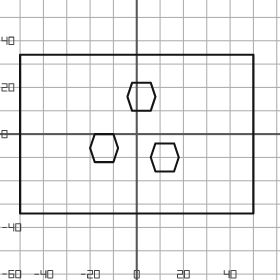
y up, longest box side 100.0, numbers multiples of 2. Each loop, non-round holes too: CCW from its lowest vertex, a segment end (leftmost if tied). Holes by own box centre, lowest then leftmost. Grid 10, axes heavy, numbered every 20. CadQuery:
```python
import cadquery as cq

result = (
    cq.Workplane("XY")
    .moveTo(-50.0, -34.0)
    .lineTo(50.0, -34.0)
    .lineTo(50.0, 34.0)
    .lineTo(-50.0, 34.0)
    .close()
    .moveTo(8.0, -16.0)
    .lineTo(16.0, -16.0)
    .lineTo(18.0, -10.0)
    .lineTo(16.0, -4.0)
    .lineTo(8.0, -4.0)
    .lineTo(6.0, -10.0)
    .close()
    .moveTo(-18.0, -12.0)
    .lineTo(-10.0, -12.0)
    .lineTo(-8.0, -6.0)
    .lineTo(-10.0, 0.0)
    .lineTo(-18.0, 0.0)
    .lineTo(-20.0, -6.0)
    .close()
    .moveTo(-2.0, 10.0)
    .lineTo(6.0, 10.0)
    .lineTo(8.0, 16.0)
    .lineTo(6.0, 22.0)
    .lineTo(-2.0, 22.0)
    .lineTo(-4.0, 16.0)
    .close()
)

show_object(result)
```